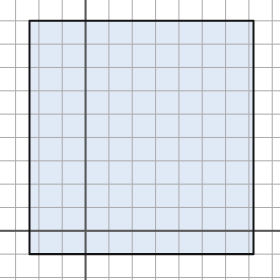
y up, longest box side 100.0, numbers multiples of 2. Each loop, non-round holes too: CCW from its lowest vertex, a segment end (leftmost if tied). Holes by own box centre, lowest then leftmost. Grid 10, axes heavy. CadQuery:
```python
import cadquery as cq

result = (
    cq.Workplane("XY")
    .moveTo(-24.0, -10.0)
    .lineTo(72.0, -10.0)
    .lineTo(72.0, 90.0)
    .lineTo(-24.0, 90.0)
    .close()
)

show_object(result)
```